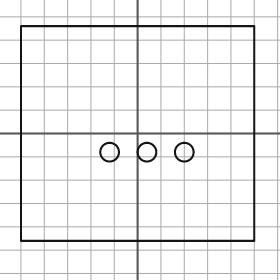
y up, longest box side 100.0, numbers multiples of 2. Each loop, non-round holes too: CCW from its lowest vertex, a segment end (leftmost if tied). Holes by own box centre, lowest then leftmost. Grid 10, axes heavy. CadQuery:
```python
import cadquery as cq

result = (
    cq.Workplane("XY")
    .moveTo(-50.0, -46.0)
    .lineTo(50.0, -46.0)
    .lineTo(50.0, 46.0)
    .lineTo(-50.0, 46.0)
    .close()
    .moveTo(-12.0, -8.0)
    .circle(4.0)
    .moveTo(4.0, -8.0)
    .circle(4.0)
    .moveTo(20.0, -8.0)
    .circle(4.0)
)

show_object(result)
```